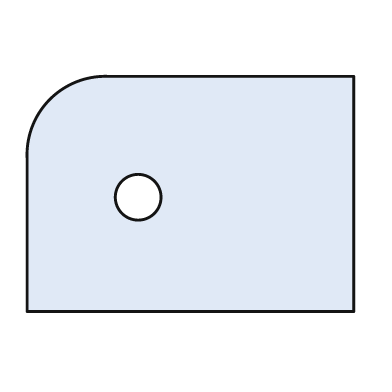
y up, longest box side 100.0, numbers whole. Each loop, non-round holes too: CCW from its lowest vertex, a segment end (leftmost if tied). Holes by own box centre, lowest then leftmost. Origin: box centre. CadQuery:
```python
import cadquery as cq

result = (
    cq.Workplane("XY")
    .moveTo(-50.0, -36.0)
    .lineTo(50.0, -36.0)
    .lineTo(50.0, 36.0)
    .lineTo(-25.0, 36.0)
    .threePointArc((-43.0, 29.0), (-50.0, 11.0))
    .close()
    .moveTo(-16.0, -1.0)
    .circle(7.0)
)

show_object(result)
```